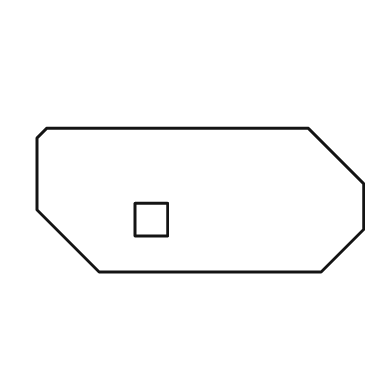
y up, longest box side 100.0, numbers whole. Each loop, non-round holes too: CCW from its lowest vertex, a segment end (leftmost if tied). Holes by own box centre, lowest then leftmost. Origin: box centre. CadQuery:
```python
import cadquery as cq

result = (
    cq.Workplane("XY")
    .moveTo(-31.0, -22.0)
    .lineTo(37.0, -22.0)
    .lineTo(50.0, -9.0)
    .lineTo(50.0, 5.0)
    .lineTo(33.0, 22.0)
    .lineTo(-47.0, 22.0)
    .lineTo(-50.0, 19.0)
    .lineTo(-50.0, -3.0)
    .close()
    .moveTo(-20.0, -11.0)
    .lineTo(-10.0, -11.0)
    .lineTo(-10.0, -1.0)
    .lineTo(-20.0, -1.0)
    .close()
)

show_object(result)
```